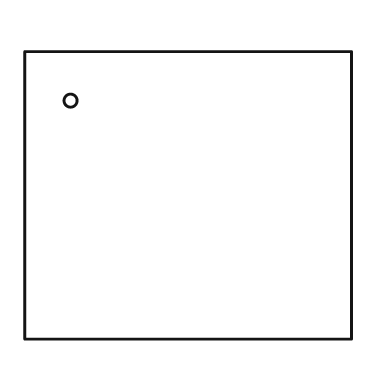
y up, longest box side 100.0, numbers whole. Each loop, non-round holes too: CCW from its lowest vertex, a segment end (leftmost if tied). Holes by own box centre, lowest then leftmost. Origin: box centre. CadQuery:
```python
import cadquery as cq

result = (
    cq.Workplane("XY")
    .moveTo(-50.0, -44.0)
    .lineTo(50.0, -44.0)
    .lineTo(50.0, 44.0)
    .lineTo(-50.0, 44.0)
    .close()
    .moveTo(-36.0, 29.0)
    .circle(2.0)
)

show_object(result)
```